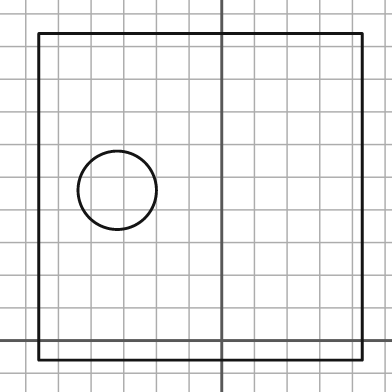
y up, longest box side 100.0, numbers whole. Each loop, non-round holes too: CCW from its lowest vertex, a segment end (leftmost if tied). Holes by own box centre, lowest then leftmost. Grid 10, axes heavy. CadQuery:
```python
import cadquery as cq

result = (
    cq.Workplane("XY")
    .moveTo(-56.0, -6.0)
    .lineTo(43.0, -6.0)
    .lineTo(43.0, 94.0)
    .lineTo(-56.0, 94.0)
    .close()
    .moveTo(-32.0, 46.0)
    .circle(12.0)
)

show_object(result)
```